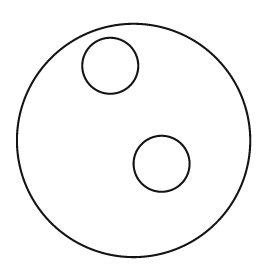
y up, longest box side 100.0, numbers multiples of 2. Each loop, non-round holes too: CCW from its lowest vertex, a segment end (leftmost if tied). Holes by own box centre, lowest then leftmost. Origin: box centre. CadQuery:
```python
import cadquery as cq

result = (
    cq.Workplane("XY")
    .moveTo(0.0, 0.0)
    .circle(50.0)
    .moveTo(12.0, -10.0)
    .circle(12.0)
    .moveTo(-10.0, 32.0)
    .circle(12.0)
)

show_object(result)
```